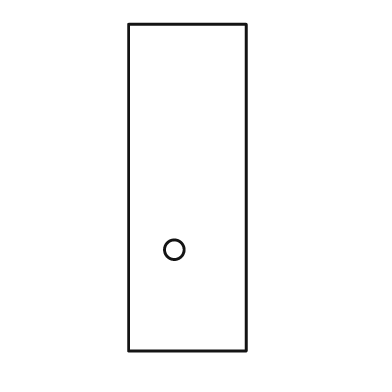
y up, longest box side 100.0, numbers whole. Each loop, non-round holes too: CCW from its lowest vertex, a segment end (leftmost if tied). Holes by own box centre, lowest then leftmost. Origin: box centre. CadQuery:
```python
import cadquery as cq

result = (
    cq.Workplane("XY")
    .moveTo(-18.0, -50.0)
    .lineTo(18.0, -50.0)
    .lineTo(18.0, 50.0)
    .lineTo(-18.0, 50.0)
    .close()
    .moveTo(-4.0, -19.0)
    .circle(3.0)
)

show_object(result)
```